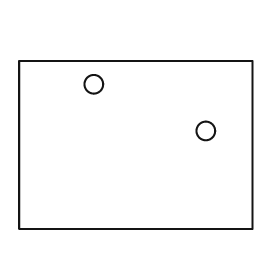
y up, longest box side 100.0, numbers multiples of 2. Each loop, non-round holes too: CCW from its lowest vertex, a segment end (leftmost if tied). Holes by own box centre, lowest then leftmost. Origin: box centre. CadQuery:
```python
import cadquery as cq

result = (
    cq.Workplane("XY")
    .moveTo(-50.0, -36.0)
    .lineTo(50.0, -36.0)
    .lineTo(50.0, 36.0)
    .lineTo(-50.0, 36.0)
    .close()
    .moveTo(30.0, 6.0)
    .circle(4.0)
    .moveTo(-18.0, 26.0)
    .circle(4.0)
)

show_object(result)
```